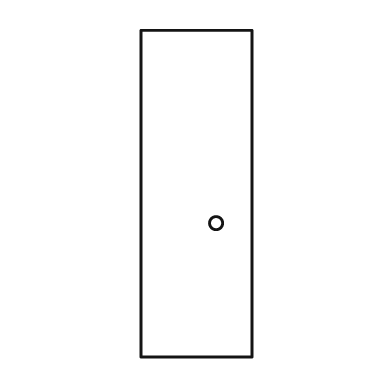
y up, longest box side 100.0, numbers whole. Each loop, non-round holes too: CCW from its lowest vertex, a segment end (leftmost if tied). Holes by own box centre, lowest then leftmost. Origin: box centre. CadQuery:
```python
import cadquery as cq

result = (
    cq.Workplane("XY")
    .moveTo(-17.0, -50.0)
    .lineTo(17.0, -50.0)
    .lineTo(17.0, 50.0)
    .lineTo(-17.0, 50.0)
    .close()
    .moveTo(6.0, -9.0)
    .circle(2.0)
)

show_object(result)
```